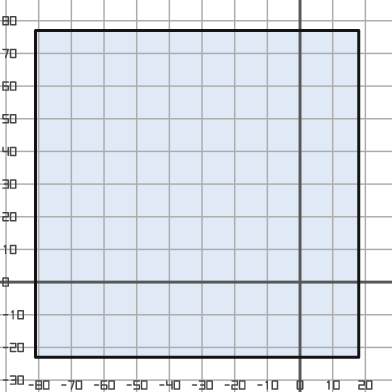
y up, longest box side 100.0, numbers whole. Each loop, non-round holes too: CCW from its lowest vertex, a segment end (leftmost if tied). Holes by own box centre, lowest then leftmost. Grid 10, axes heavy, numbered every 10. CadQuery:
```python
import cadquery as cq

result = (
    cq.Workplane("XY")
    .moveTo(-81.0, -23.0)
    .lineTo(18.0, -23.0)
    .lineTo(18.0, 77.0)
    .lineTo(-81.0, 77.0)
    .close()
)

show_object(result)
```